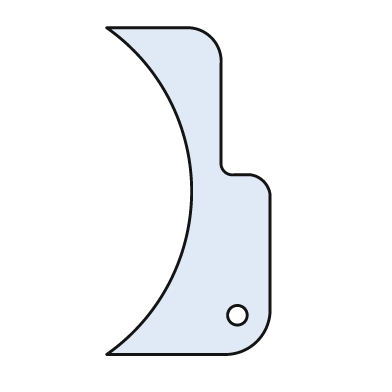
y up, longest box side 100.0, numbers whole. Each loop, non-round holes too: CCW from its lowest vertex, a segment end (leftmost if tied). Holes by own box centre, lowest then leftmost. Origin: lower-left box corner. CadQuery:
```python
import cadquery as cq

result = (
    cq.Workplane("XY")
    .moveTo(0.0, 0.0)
    .lineTo(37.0, 0.0)
    .threePointArc((46.0, 4.0), (50.0, 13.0))
    .lineTo(50.0, 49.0)
    .threePointArc((48.0, 53.0), (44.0, 55.0))
    .lineTo(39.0, 55.0)
    .threePointArc((36.0, 56.0), (35.0, 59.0))
    .lineTo(35.0, 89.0)
    .threePointArc((32.0, 97.0), (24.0, 100.0))
    .lineTo(0.0, 100.0)
    .threePointArc((26.0, 50.0), (0.0, 0.0))
    .close()
    .moveTo(40.0, 12.0)
    .circle(3.0)
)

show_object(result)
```